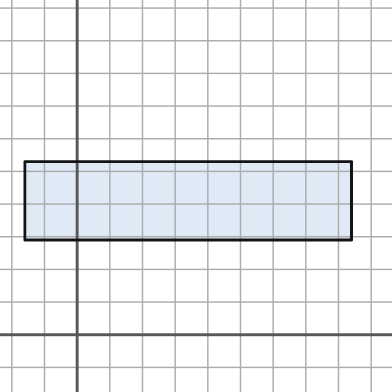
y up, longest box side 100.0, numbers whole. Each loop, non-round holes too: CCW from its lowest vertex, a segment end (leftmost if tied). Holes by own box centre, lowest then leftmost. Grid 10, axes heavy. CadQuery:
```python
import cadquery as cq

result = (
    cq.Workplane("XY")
    .moveTo(-16.0, 29.0)
    .lineTo(84.0, 29.0)
    .lineTo(84.0, 53.0)
    .lineTo(-16.0, 53.0)
    .close()
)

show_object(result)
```